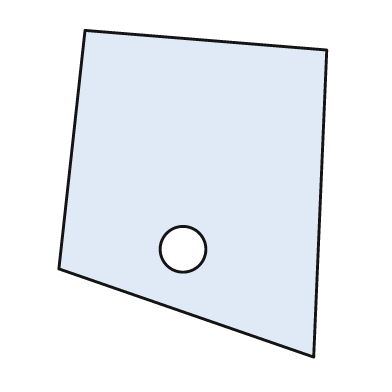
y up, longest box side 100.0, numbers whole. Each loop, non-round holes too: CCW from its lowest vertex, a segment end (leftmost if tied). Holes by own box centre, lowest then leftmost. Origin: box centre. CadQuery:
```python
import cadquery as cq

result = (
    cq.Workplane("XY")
    .moveTo(37.0, -50.0)
    .lineTo(41.0, 44.0)
    .lineTo(-33.0, 50.0)
    .lineTo(-41.0, -23.0)
    .close()
    .moveTo(-3.0, -17.0)
    .circle(7.0)
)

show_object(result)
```